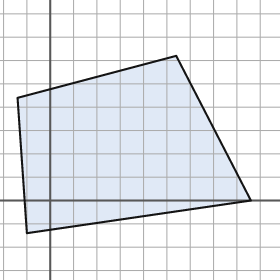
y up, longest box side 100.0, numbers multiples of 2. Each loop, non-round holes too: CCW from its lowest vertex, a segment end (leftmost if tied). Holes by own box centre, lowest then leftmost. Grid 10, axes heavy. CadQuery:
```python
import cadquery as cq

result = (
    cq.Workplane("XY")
    .moveTo(-10.0, -14.0)
    .lineTo(86.0, 0.0)
    .lineTo(54.0, 62.0)
    .lineTo(-14.0, 44.0)
    .close()
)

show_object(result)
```